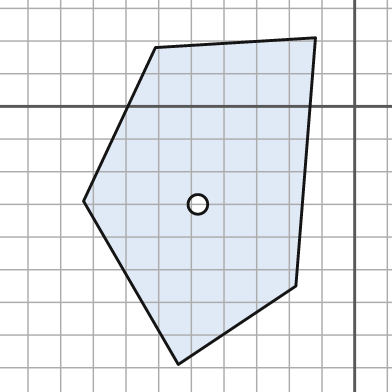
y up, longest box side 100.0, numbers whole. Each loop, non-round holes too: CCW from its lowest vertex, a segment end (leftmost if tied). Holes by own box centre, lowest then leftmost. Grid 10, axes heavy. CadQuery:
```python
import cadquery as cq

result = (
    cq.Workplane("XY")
    .moveTo(-54.0, -79.0)
    .lineTo(-18.0, -55.0)
    .lineTo(-12.0, 21.0)
    .lineTo(-61.0, 18.0)
    .lineTo(-83.0, -29.0)
    .close()
    .moveTo(-48.0, -30.0)
    .circle(3.0)
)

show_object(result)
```